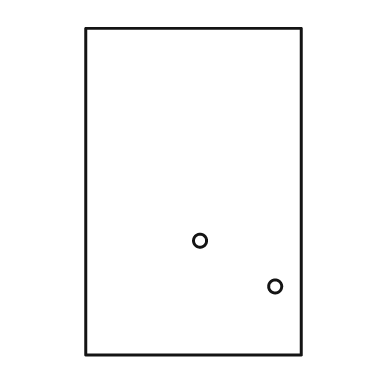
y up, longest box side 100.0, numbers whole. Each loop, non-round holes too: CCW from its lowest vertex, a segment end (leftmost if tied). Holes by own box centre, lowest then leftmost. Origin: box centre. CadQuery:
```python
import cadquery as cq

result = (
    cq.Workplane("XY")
    .moveTo(-33.0, -50.0)
    .lineTo(33.0, -50.0)
    .lineTo(33.0, 50.0)
    .lineTo(-33.0, 50.0)
    .close()
    .moveTo(25.0, -29.0)
    .circle(2.0)
    .moveTo(2.0, -15.0)
    .circle(2.0)
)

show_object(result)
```